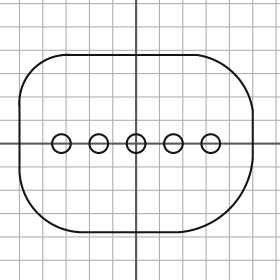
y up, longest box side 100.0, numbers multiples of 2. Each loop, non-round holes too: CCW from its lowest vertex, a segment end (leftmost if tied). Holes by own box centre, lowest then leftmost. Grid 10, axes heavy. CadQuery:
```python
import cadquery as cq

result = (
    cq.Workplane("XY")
    .moveTo(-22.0, -38.0)
    .lineTo(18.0, -38.0)
    .threePointArc((40.0, -28.0), (50.0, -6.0))
    .lineTo(50.0, 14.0)
    .threePointArc((42.0, 30.0), (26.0, 38.0))
    .lineTo(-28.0, 38.0)
    .threePointArc((-44.0, 32.0), (-50.0, 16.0))
    .lineTo(-50.0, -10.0)
    .threePointArc((-42.0, -30.0), (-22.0, -38.0))
    .close()
    .moveTo(-32.0, 0.0)
    .circle(4.0)
    .moveTo(-16.0, 0.0)
    .circle(4.0)
    .moveTo(0.0, 0.0)
    .circle(4.0)
    .moveTo(16.0, 0.0)
    .circle(4.0)
    .moveTo(32.0, 0.0)
    .circle(4.0)
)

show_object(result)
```